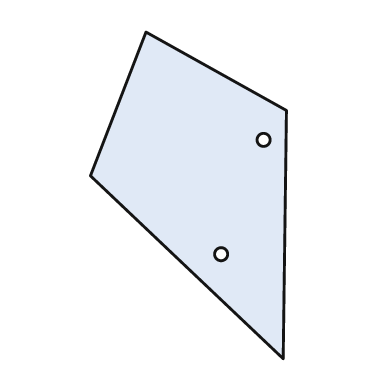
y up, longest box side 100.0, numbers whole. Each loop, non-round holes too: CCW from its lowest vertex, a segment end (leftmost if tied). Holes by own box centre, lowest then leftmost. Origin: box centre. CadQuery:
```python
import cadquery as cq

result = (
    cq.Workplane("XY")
    .moveTo(29.0, -50.0)
    .lineTo(30.0, 26.0)
    .lineTo(-13.0, 50.0)
    .lineTo(-30.0, 6.0)
    .close()
    .moveTo(10.0, -18.0)
    .circle(2.0)
    .moveTo(23.0, 17.0)
    .circle(2.0)
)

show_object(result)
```